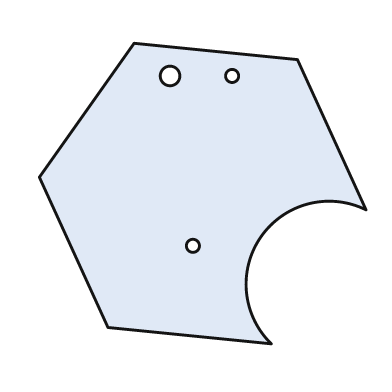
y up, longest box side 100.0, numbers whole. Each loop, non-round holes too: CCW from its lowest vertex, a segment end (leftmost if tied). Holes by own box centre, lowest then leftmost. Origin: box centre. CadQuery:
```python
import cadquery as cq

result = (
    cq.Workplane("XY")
    .moveTo(21.0, -46.0)
    .threePointArc((18.0, -13.0), (50.0, -5.0))
    .lineTo(29.0, 41.0)
    .lineTo(-21.0, 46.0)
    .lineTo(-50.0, 5.0)
    .lineTo(-29.0, -41.0)
    .close()
    .moveTo(-3.0, -16.0)
    .circle(2.0)
    .moveTo(-10.0, 36.0)
    .circle(3.0)
    .moveTo(9.0, 36.0)
    .circle(2.0)
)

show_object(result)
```